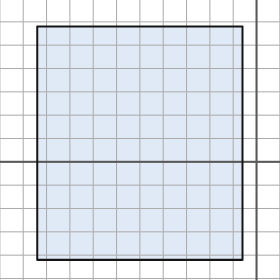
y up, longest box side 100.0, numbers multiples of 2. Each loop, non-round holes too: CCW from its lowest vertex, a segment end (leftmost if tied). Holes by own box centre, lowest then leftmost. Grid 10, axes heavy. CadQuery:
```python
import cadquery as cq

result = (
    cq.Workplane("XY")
    .moveTo(-94.0, -42.0)
    .lineTo(-6.0, -42.0)
    .lineTo(-6.0, 58.0)
    .lineTo(-94.0, 58.0)
    .close()
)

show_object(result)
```